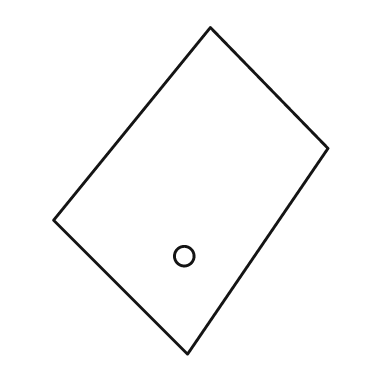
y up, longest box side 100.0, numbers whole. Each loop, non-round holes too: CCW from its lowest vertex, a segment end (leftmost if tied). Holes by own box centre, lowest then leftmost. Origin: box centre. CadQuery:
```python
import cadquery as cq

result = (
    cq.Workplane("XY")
    .moveTo(-1.0, -50.0)
    .lineTo(42.0, 13.0)
    .lineTo(6.0, 50.0)
    .lineTo(-42.0, -9.0)
    .close()
    .moveTo(-2.0, -20.0)
    .circle(3.0)
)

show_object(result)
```